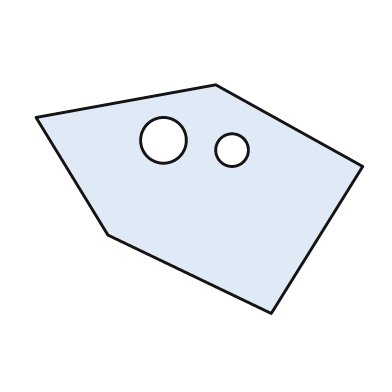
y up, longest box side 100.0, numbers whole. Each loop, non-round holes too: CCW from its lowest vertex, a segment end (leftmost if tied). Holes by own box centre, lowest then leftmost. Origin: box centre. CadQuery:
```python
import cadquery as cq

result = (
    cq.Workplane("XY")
    .moveTo(22.0, -35.0)
    .lineTo(50.0, 10.0)
    .lineTo(5.0, 35.0)
    .lineTo(-50.0, 25.0)
    .lineTo(-28.0, -11.0)
    .close()
    .moveTo(10.0, 15.0)
    .circle(5.0)
    .moveTo(-11.0, 18.0)
    .circle(7.0)
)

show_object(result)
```